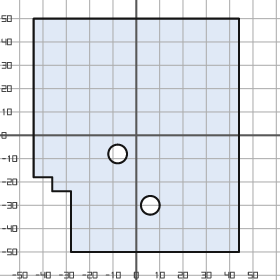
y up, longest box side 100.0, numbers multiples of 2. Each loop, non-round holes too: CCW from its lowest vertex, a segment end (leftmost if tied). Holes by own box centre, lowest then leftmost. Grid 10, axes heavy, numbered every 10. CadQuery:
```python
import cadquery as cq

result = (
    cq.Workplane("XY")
    .moveTo(-28.0, -50.0)
    .lineTo(44.0, -50.0)
    .lineTo(44.0, 50.0)
    .lineTo(-44.0, 50.0)
    .lineTo(-44.0, -18.0)
    .lineTo(-36.0, -18.0)
    .lineTo(-36.0, -24.0)
    .lineTo(-28.0, -24.0)
    .close()
    .moveTo(6.0, -30.0)
    .circle(4.0)
    .moveTo(-8.0, -8.0)
    .circle(4.0)
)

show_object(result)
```